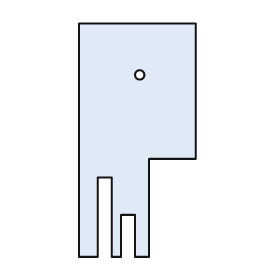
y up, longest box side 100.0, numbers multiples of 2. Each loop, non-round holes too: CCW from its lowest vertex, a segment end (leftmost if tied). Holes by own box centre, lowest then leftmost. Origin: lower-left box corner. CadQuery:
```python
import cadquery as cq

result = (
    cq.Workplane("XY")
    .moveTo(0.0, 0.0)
    .lineTo(8.0, 0.0)
    .lineTo(8.0, 34.0)
    .lineTo(14.0, 34.0)
    .lineTo(14.0, 0.0)
    .lineTo(18.0, 0.0)
    .lineTo(18.0, 18.0)
    .lineTo(24.0, 18.0)
    .lineTo(24.0, 0.0)
    .lineTo(30.0, 0.0)
    .lineTo(30.0, 42.0)
    .lineTo(50.0, 42.0)
    .lineTo(50.0, 100.0)
    .lineTo(0.0, 100.0)
    .close()
    .moveTo(26.0, 78.0)
    .circle(2.0)
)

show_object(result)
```